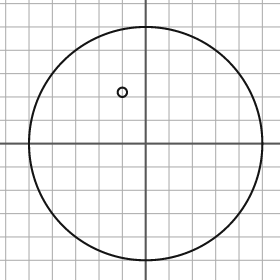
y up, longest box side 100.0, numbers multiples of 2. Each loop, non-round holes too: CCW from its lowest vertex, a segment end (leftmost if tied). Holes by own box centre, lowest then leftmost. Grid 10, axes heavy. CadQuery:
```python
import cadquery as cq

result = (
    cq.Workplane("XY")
    .moveTo(0.0, 0.0)
    .circle(50.0)
    .moveTo(-10.0, 22.0)
    .circle(2.0)
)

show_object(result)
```